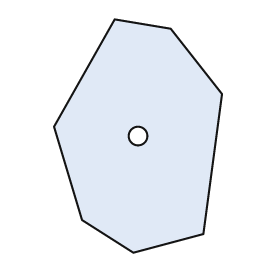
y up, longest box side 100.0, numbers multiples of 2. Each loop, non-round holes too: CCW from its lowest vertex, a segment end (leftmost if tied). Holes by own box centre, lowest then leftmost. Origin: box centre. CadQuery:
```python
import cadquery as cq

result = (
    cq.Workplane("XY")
    .moveTo(-2.0, -50.0)
    .lineTo(28.0, -42.0)
    .lineTo(36.0, 18.0)
    .lineTo(14.0, 46.0)
    .lineTo(-10.0, 50.0)
    .lineTo(-36.0, 4.0)
    .lineTo(-24.0, -36.0)
    .close()
    .moveTo(0.0, 0.0)
    .circle(4.0)
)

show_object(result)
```